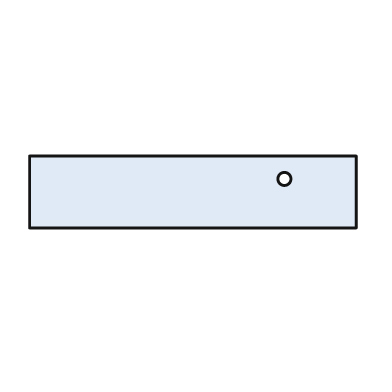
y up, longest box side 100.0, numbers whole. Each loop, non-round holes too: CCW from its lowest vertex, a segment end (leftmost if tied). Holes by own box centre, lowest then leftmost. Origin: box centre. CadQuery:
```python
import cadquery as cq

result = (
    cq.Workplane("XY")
    .moveTo(-50.0, -11.0)
    .lineTo(50.0, -11.0)
    .lineTo(50.0, 11.0)
    .lineTo(-50.0, 11.0)
    .close()
    .moveTo(28.0, 4.0)
    .circle(2.0)
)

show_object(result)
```